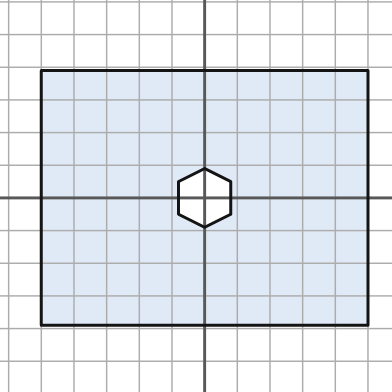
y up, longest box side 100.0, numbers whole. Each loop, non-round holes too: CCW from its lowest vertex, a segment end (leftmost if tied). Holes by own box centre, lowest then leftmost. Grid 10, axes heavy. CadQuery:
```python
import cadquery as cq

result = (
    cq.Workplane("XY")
    .moveTo(-50.0, -39.0)
    .lineTo(50.0, -39.0)
    .lineTo(50.0, 39.0)
    .lineTo(-50.0, 39.0)
    .close()
    .moveTo(0.0, -9.0)
    .lineTo(8.0, -5.0)
    .lineTo(8.0, 5.0)
    .lineTo(0.0, 9.0)
    .lineTo(-8.0, 5.0)
    .lineTo(-8.0, -5.0)
    .close()
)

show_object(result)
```